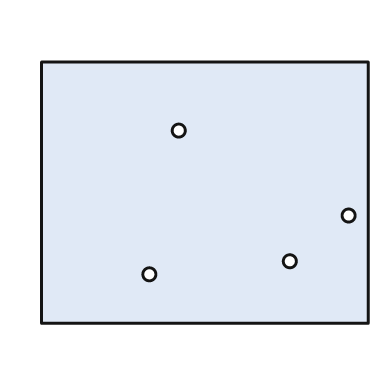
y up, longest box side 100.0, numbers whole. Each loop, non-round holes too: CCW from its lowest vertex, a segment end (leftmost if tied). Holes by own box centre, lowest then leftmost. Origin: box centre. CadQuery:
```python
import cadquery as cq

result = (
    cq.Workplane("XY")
    .moveTo(-50.0, -40.0)
    .lineTo(50.0, -40.0)
    .lineTo(50.0, 40.0)
    .lineTo(-50.0, 40.0)
    .close()
    .moveTo(-17.0, -25.0)
    .circle(2.0)
    .moveTo(26.0, -21.0)
    .circle(2.0)
    .moveTo(44.0, -7.0)
    .circle(2.0)
    .moveTo(-8.0, 19.0)
    .circle(2.0)
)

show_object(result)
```